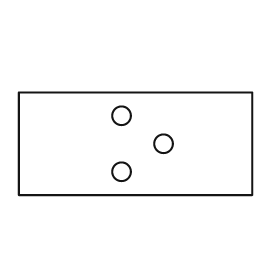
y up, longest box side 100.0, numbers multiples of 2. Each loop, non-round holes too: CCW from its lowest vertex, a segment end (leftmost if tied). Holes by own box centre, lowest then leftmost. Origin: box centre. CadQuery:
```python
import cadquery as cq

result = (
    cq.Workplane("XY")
    .moveTo(-50.0, -22.0)
    .lineTo(50.0, -22.0)
    .lineTo(50.0, 22.0)
    .lineTo(-50.0, 22.0)
    .close()
    .moveTo(-6.0, -12.0)
    .circle(4.0)
    .moveTo(12.0, 0.0)
    .circle(4.0)
    .moveTo(-6.0, 12.0)
    .circle(4.0)
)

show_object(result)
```